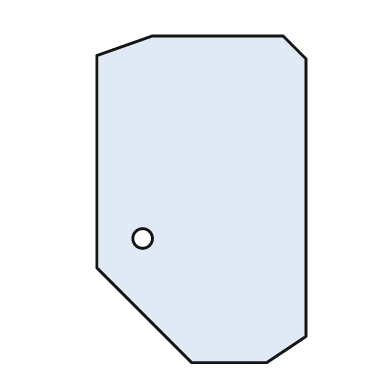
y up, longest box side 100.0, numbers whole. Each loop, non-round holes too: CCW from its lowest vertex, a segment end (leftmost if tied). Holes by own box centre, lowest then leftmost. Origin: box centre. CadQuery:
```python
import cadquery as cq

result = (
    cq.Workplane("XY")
    .moveTo(-3.0, -50.0)
    .lineTo(20.0, -50.0)
    .lineTo(32.0, -42.0)
    .lineTo(32.0, 43.0)
    .lineTo(25.0, 50.0)
    .lineTo(-15.0, 50.0)
    .lineTo(-32.0, 44.0)
    .lineTo(-32.0, -21.0)
    .close()
    .moveTo(-18.0, -12.0)
    .circle(3.0)
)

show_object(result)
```